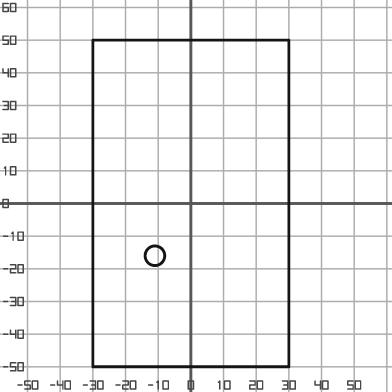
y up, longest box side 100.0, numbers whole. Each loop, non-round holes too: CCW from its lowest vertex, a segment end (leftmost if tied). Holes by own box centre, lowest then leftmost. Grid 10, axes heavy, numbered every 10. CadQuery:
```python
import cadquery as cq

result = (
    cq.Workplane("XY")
    .moveTo(-30.0, -50.0)
    .lineTo(30.0, -50.0)
    .lineTo(30.0, 50.0)
    .lineTo(-30.0, 50.0)
    .close()
    .moveTo(-11.0, -16.0)
    .circle(3.0)
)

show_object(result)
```